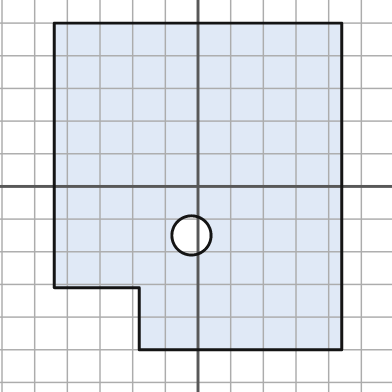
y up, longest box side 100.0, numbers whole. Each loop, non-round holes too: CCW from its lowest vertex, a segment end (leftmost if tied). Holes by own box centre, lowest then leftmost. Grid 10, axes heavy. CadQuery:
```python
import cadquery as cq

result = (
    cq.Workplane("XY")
    .moveTo(-18.0, -50.0)
    .lineTo(44.0, -50.0)
    .lineTo(44.0, 50.0)
    .lineTo(-44.0, 50.0)
    .lineTo(-44.0, -31.0)
    .lineTo(-18.0, -31.0)
    .close()
    .moveTo(-2.0, -15.0)
    .circle(6.0)
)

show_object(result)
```